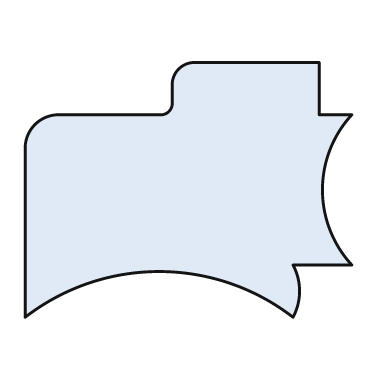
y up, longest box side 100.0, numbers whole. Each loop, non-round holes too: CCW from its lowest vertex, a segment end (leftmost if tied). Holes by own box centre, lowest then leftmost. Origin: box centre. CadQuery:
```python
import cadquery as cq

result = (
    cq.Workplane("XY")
    .moveTo(-50.0, -39.0)
    .threePointArc((-9.0, -25.0), (32.0, -39.0))
    .threePointArc((34.0, -31.0), (32.0, -23.0))
    .lineTo(50.0, -23.0)
    .threePointArc((41.0, 0.0), (50.0, 23.0))
    .lineTo(40.0, 23.0)
    .lineTo(40.0, 39.0)
    .lineTo(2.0, 39.0)
    .threePointArc((-3.0, 37.0), (-5.0, 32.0))
    .lineTo(-5.0, 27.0)
    .threePointArc((-6.0, 24.0), (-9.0, 23.0))
    .lineTo(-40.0, 23.0)
    .threePointArc((-47.0, 20.0), (-50.0, 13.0))
    .close()
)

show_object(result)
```